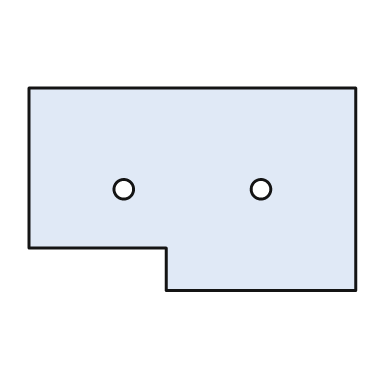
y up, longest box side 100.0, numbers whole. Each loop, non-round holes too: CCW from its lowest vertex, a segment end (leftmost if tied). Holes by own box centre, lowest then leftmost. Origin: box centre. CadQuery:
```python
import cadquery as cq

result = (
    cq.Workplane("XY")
    .moveTo(-8.0, -31.0)
    .lineTo(50.0, -31.0)
    .lineTo(50.0, 31.0)
    .lineTo(-50.0, 31.0)
    .lineTo(-50.0, -18.0)
    .lineTo(-8.0, -18.0)
    .close()
    .moveTo(-21.0, 0.0)
    .circle(3.0)
    .moveTo(21.0, 0.0)
    .circle(3.0)
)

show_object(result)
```